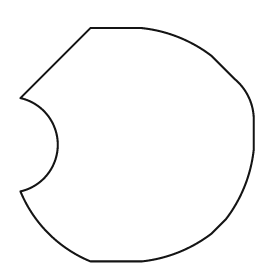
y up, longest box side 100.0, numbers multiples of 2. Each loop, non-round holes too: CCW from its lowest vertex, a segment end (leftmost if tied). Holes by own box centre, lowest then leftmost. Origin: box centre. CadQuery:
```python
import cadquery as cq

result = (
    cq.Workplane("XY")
    .moveTo(-20.0, -50.0)
    .lineTo(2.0, -50.0)
    .threePointArc((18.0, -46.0), (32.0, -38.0))
    .lineTo(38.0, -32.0)
    .threePointArc((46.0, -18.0), (50.0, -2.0))
    .lineTo(50.0, 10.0)
    .threePointArc((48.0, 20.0), (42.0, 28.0))
    .lineTo(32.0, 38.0)
    .threePointArc((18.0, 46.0), (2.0, 50.0))
    .lineTo(-20.0, 50.0)
    .lineTo(-50.0, 20.0)
    .threePointArc((-34.0, 0.0), (-50.0, -20.0))
    .threePointArc((-38.0, -38.0), (-20.0, -50.0))
    .close()
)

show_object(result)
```